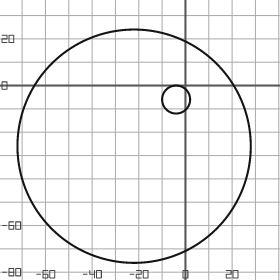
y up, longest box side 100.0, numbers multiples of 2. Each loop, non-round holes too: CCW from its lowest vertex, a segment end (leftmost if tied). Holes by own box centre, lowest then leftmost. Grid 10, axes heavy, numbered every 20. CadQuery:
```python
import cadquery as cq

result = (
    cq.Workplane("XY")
    .moveTo(-22.0, -26.0)
    .circle(50.0)
    .moveTo(-4.0, -6.0)
    .circle(6.0)
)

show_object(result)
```